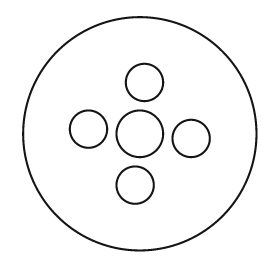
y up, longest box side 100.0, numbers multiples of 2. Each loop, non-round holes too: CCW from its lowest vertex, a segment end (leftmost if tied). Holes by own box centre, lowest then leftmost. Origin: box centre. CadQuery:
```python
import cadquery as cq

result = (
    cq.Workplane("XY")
    .moveTo(0.0, 0.0)
    .circle(50.0)
    .moveTo(-2.0, -22.0)
    .circle(8.0)
    .moveTo(22.0, -2.0)
    .circle(8.0)
    .moveTo(0.0, 0.0)
    .circle(10.0)
    .moveTo(-22.0, 2.0)
    .circle(8.0)
    .moveTo(2.0, 22.0)
    .circle(8.0)
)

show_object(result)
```